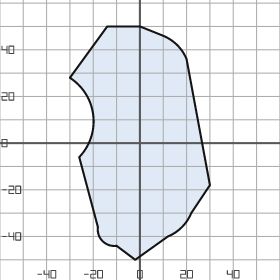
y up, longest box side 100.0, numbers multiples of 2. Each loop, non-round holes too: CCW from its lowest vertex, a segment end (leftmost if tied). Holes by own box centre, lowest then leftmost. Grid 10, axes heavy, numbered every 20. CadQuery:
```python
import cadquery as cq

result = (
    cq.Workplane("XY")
    .moveTo(-2.0, -50.0)
    .lineTo(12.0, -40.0)
    .threePointArc((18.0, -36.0), (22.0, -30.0))
    .lineTo(30.0, -18.0)
    .lineTo(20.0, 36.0)
    .threePointArc((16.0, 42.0), (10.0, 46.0))
    .lineTo(0.0, 50.0)
    .lineTo(-14.0, 50.0)
    .lineTo(-30.0, 28.0)
    .threePointArc((-20.0, 12.0), (-26.0, -6.0))
    .lineTo(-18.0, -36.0)
    .threePointArc((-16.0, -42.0), (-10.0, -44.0))
    .close()
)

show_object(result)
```